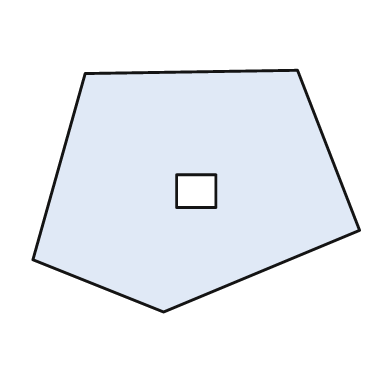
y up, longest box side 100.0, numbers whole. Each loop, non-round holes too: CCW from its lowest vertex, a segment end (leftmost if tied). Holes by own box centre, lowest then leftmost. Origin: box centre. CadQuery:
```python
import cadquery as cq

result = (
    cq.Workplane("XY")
    .moveTo(-10.0, -37.0)
    .lineTo(50.0, -12.0)
    .lineTo(31.0, 37.0)
    .lineTo(-34.0, 36.0)
    .lineTo(-50.0, -21.0)
    .close()
    .moveTo(-6.0, -5.0)
    .lineTo(6.0, -5.0)
    .lineTo(6.0, 5.0)
    .lineTo(-6.0, 5.0)
    .close()
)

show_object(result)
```